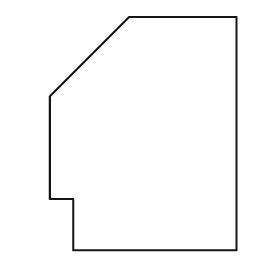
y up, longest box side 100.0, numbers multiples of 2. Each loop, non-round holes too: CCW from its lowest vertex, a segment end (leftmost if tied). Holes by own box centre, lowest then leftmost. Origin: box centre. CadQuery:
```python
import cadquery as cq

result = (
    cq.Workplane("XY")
    .moveTo(-30.0, -50.0)
    .lineTo(40.0, -50.0)
    .lineTo(40.0, 50.0)
    .lineTo(-6.0, 50.0)
    .lineTo(-40.0, 16.0)
    .lineTo(-40.0, -28.0)
    .lineTo(-30.0, -28.0)
    .close()
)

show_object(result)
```